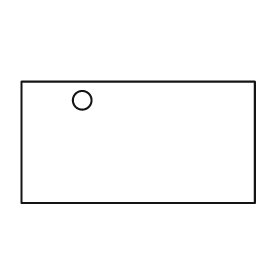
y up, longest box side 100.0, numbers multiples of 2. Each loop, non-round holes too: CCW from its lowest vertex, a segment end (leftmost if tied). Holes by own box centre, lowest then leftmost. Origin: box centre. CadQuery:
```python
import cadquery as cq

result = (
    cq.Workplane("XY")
    .moveTo(-50.0, -26.0)
    .lineTo(50.0, -26.0)
    .lineTo(50.0, 26.0)
    .lineTo(-50.0, 26.0)
    .close()
    .moveTo(-24.0, 18.0)
    .circle(4.0)
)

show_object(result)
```